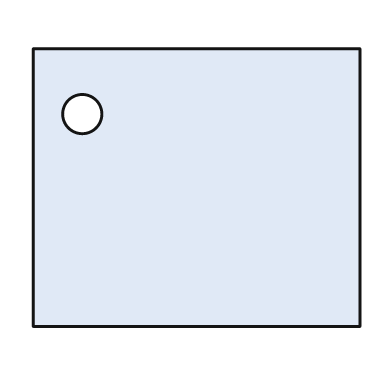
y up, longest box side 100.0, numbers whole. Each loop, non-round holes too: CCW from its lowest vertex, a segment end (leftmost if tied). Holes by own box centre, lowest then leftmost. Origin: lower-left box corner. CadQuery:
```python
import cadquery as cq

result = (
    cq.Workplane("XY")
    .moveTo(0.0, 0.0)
    .lineTo(100.0, 0.0)
    .lineTo(100.0, 85.0)
    .lineTo(0.0, 85.0)
    .close()
    .moveTo(15.0, 65.0)
    .circle(6.0)
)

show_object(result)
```